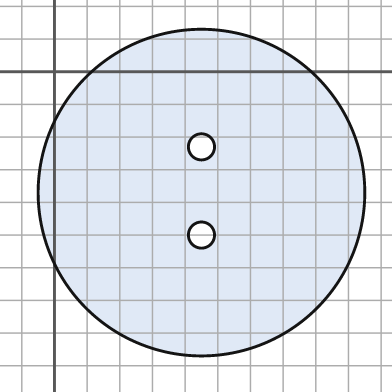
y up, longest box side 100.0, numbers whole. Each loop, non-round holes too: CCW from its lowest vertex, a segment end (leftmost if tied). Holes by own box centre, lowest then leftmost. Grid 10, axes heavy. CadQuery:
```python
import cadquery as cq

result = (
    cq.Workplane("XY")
    .moveTo(45.0, -37.0)
    .circle(50.0)
    .moveTo(45.0, -50.0)
    .circle(4.0)
    .moveTo(45.0, -23.0)
    .circle(4.0)
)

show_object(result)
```